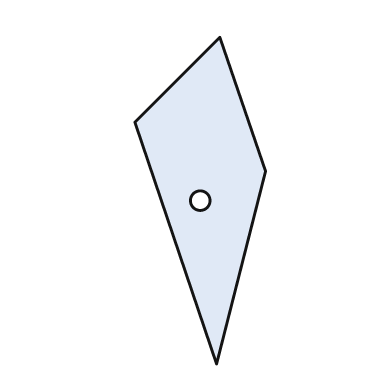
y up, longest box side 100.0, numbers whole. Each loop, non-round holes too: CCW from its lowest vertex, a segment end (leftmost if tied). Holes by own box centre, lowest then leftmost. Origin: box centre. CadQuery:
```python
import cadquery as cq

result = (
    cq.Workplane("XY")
    .moveTo(5.0, -50.0)
    .lineTo(20.0, 9.0)
    .lineTo(6.0, 50.0)
    .lineTo(-20.0, 24.0)
    .close()
    .moveTo(0.0, 0.0)
    .circle(3.0)
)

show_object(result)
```